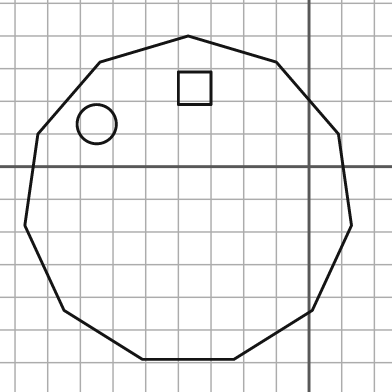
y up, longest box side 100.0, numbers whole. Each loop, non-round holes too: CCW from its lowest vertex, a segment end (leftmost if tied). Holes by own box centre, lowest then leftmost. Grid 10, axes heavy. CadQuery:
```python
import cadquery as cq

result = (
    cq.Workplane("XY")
    .moveTo(-51.0, -59.0)
    .lineTo(-23.0, -59.0)
    .lineTo(1.0, -44.0)
    .lineTo(13.0, -18.0)
    .lineTo(9.0, 10.0)
    .lineTo(-10.0, 32.0)
    .lineTo(-37.0, 40.0)
    .lineTo(-64.0, 32.0)
    .lineTo(-83.0, 10.0)
    .lineTo(-87.0, -18.0)
    .lineTo(-75.0, -44.0)
    .close()
    .moveTo(-65.0, 13.0)
    .circle(6.0)
    .moveTo(-40.0, 19.0)
    .lineTo(-30.0, 19.0)
    .lineTo(-30.0, 29.0)
    .lineTo(-40.0, 29.0)
    .close()
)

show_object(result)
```